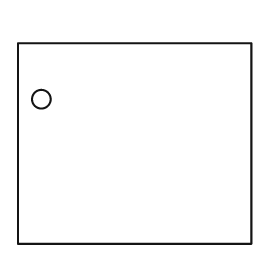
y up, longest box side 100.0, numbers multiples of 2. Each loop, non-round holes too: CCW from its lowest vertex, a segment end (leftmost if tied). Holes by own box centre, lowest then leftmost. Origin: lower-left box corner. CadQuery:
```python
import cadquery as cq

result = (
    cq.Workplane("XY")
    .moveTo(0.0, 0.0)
    .lineTo(100.0, 0.0)
    .lineTo(100.0, 86.0)
    .lineTo(0.0, 86.0)
    .close()
    .moveTo(10.0, 62.0)
    .circle(4.0)
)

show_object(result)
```